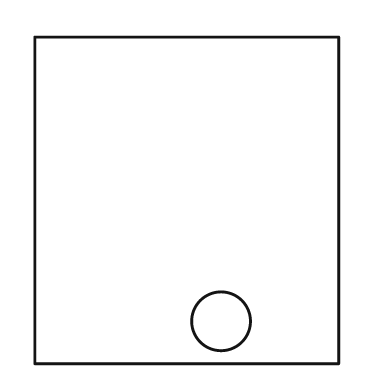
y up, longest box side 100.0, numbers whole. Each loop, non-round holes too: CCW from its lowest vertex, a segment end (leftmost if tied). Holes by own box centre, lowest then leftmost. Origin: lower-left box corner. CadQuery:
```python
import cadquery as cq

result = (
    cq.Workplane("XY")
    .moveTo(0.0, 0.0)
    .lineTo(93.0, 0.0)
    .lineTo(93.0, 100.0)
    .lineTo(0.0, 100.0)
    .close()
    .moveTo(57.0, 13.0)
    .circle(9.0)
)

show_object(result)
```